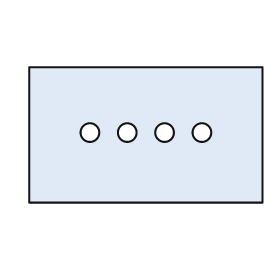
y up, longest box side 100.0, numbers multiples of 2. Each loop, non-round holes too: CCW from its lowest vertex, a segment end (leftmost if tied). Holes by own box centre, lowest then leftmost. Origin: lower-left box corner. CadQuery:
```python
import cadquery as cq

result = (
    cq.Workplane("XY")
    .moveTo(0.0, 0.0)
    .lineTo(100.0, 0.0)
    .lineTo(100.0, 58.0)
    .lineTo(0.0, 58.0)
    .close()
    .moveTo(26.0, 30.0)
    .circle(4.0)
    .moveTo(42.0, 30.0)
    .circle(4.0)
    .moveTo(58.0, 30.0)
    .circle(4.0)
    .moveTo(74.0, 30.0)
    .circle(4.0)
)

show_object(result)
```